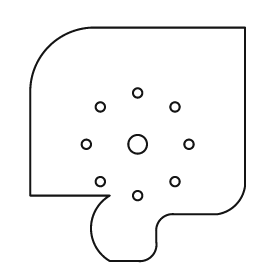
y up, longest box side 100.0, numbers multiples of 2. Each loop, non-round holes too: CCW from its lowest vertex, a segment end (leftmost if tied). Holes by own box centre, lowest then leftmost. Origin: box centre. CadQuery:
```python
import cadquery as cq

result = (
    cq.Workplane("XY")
    .moveTo(-12.0, -50.0)
    .lineTo(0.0, -50.0)
    .threePointArc((6.0, -48.0), (8.0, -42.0))
    .lineTo(8.0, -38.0)
    .threePointArc((10.0, -32.0), (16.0, -30.0))
    .lineTo(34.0, -30.0)
    .threePointArc((42.0, -26.0), (46.0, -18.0))
    .lineTo(46.0, 50.0)
    .lineTo(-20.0, 50.0)
    .threePointArc((-38.0, 42.0), (-46.0, 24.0))
    .lineTo(-46.0, -22.0)
    .lineTo(-12.0, -22.0)
    .threePointArc((-20.0, -36.0), (-12.0, -50.0))
    .close()
    .moveTo(0.0, -22.0)
    .circle(2.0)
    .moveTo(-16.0, -16.0)
    .circle(2.0)
    .moveTo(16.0, -16.0)
    .circle(2.0)
    .moveTo(-22.0, 0.0)
    .circle(2.0)
    .moveTo(0.0, 0.0)
    .circle(4.0)
    .moveTo(22.0, 0.0)
    .circle(2.0)
    .moveTo(-16.0, 16.0)
    .circle(2.0)
    .moveTo(16.0, 16.0)
    .circle(2.0)
    .moveTo(0.0, 22.0)
    .circle(2.0)
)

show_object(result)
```